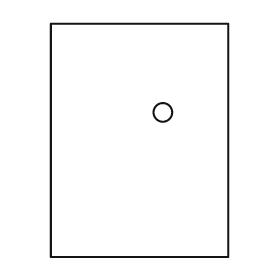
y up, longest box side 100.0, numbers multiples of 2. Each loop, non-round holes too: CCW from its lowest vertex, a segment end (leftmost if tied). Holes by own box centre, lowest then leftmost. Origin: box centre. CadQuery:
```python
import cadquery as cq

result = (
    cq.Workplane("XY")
    .moveTo(-38.0, -50.0)
    .lineTo(38.0, -50.0)
    .lineTo(38.0, 50.0)
    .lineTo(-38.0, 50.0)
    .close()
    .moveTo(10.0, 12.0)
    .circle(4.0)
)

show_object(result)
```